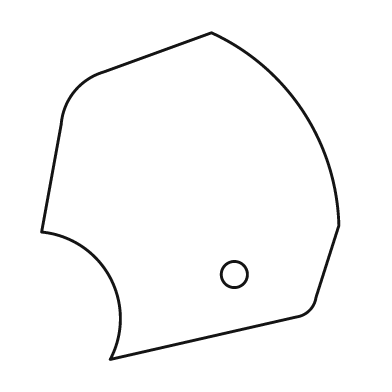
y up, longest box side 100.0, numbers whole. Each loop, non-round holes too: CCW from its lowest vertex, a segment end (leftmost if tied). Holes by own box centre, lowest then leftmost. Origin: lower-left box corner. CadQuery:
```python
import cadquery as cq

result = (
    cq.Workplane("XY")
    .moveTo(21.0, 0.0)
    .lineTo(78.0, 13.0)
    .threePointArc((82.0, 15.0), (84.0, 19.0))
    .lineTo(91.0, 41.0)
    .threePointArc((80.0, 76.0), (52.0, 100.0))
    .lineTo(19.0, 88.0)
    .threePointArc((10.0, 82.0), (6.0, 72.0))
    .lineTo(0.0, 39.0)
    .threePointArc((21.0, 25.0), (21.0, 0.0))
    .close()
    .moveTo(59.0, 26.0)
    .circle(4.0)
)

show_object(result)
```